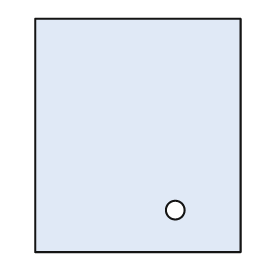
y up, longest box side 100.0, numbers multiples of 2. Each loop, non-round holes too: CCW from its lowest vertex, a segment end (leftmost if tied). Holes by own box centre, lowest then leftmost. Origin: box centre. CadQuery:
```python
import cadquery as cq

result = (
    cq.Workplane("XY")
    .moveTo(-44.0, -50.0)
    .lineTo(44.0, -50.0)
    .lineTo(44.0, 50.0)
    .lineTo(-44.0, 50.0)
    .close()
    .moveTo(16.0, -32.0)
    .circle(4.0)
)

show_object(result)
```